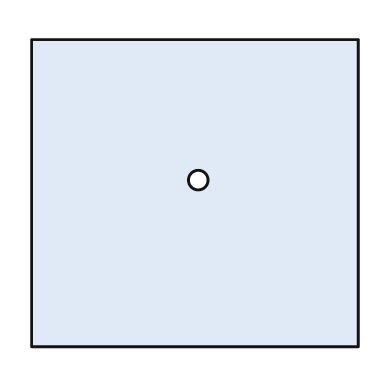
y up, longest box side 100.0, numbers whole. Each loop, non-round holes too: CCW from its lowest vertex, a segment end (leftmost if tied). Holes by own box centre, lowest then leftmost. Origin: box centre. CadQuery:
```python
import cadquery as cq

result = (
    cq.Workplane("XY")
    .moveTo(-50.0, -47.0)
    .lineTo(50.0, -47.0)
    .lineTo(50.0, 47.0)
    .lineTo(-50.0, 47.0)
    .close()
    .moveTo(1.0, 4.0)
    .circle(3.0)
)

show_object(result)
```